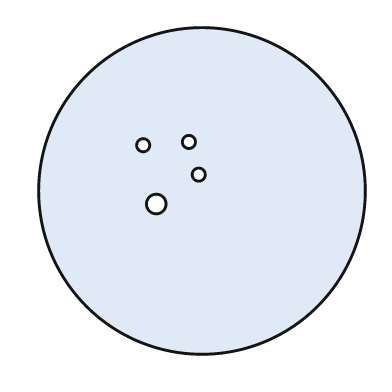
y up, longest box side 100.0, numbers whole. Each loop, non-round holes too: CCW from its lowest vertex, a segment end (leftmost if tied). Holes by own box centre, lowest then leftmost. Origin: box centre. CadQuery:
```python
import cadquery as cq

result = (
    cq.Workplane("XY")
    .moveTo(0.0, 0.0)
    .circle(50.0)
    .moveTo(-14.0, -4.0)
    .circle(3.0)
    .moveTo(-1.0, 5.0)
    .circle(2.0)
    .moveTo(-18.0, 14.0)
    .circle(2.0)
    .moveTo(-4.0, 15.0)
    .circle(2.0)
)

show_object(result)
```